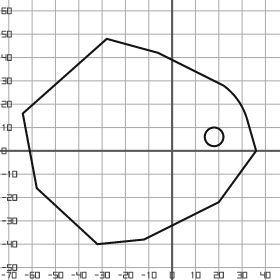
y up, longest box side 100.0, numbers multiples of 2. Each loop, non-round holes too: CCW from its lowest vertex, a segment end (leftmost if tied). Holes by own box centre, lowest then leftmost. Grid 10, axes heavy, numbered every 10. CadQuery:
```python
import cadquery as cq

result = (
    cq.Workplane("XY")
    .moveTo(-32.0, -40.0)
    .lineTo(-12.0, -38.0)
    .lineTo(20.0, -22.0)
    .lineTo(36.0, 0.0)
    .lineTo(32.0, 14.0)
    .threePointArc((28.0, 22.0), (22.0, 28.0))
    .lineTo(-6.0, 42.0)
    .lineTo(-28.0, 48.0)
    .lineTo(-64.0, 16.0)
    .lineTo(-58.0, -16.0)
    .close()
    .moveTo(18.0, 6.0)
    .circle(4.0)
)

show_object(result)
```